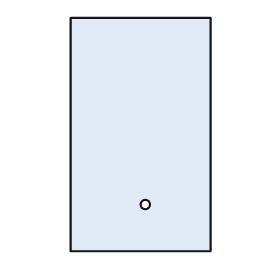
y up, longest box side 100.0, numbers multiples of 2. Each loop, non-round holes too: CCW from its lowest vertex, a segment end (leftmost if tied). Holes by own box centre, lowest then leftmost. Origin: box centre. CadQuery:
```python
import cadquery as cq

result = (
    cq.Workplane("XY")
    .moveTo(-30.0, -50.0)
    .lineTo(30.0, -50.0)
    .lineTo(30.0, 50.0)
    .lineTo(-30.0, 50.0)
    .close()
    .moveTo(2.0, -30.0)
    .circle(2.0)
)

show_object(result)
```